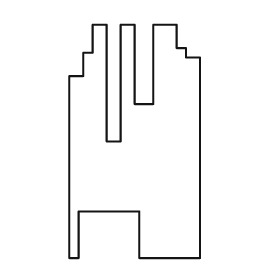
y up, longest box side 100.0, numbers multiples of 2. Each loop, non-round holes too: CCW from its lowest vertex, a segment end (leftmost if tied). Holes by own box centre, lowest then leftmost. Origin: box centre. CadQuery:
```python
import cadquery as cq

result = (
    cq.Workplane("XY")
    .moveTo(-28.0, -50.0)
    .lineTo(-24.0, -50.0)
    .lineTo(-24.0, -30.0)
    .lineTo(2.0, -30.0)
    .lineTo(2.0, -50.0)
    .lineTo(28.0, -50.0)
    .lineTo(28.0, 36.0)
    .lineTo(22.0, 36.0)
    .lineTo(22.0, 40.0)
    .lineTo(18.0, 40.0)
    .lineTo(18.0, 50.0)
    .lineTo(8.0, 50.0)
    .lineTo(8.0, 16.0)
    .lineTo(0.0, 16.0)
    .lineTo(0.0, 50.0)
    .lineTo(-6.0, 50.0)
    .lineTo(-6.0, 0.0)
    .lineTo(-12.0, 0.0)
    .lineTo(-12.0, 50.0)
    .lineTo(-18.0, 50.0)
    .lineTo(-18.0, 38.0)
    .lineTo(-22.0, 38.0)
    .lineTo(-22.0, 28.0)
    .lineTo(-28.0, 28.0)
    .close()
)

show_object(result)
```